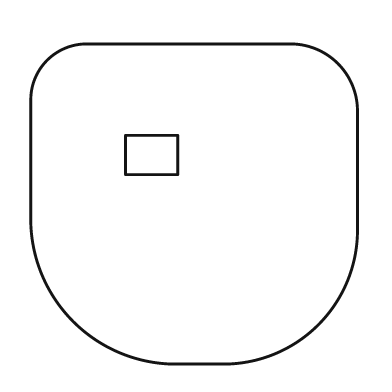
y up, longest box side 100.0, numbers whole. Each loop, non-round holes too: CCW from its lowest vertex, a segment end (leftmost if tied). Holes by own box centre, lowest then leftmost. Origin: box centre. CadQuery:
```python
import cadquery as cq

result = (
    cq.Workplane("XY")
    .moveTo(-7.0, -49.0)
    .lineTo(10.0, -49.0)
    .threePointArc((38.0, -37.0), (50.0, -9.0))
    .lineTo(50.0, 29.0)
    .threePointArc((44.0, 43.0), (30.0, 49.0))
    .lineTo(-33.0, 49.0)
    .threePointArc((-45.0, 44.0), (-50.0, 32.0))
    .lineTo(-50.0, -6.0)
    .threePointArc((-37.0, -36.0), (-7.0, -49.0))
    .close()
    .moveTo(-21.0, 9.0)
    .lineTo(-5.0, 9.0)
    .lineTo(-5.0, 21.0)
    .lineTo(-21.0, 21.0)
    .close()
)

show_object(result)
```